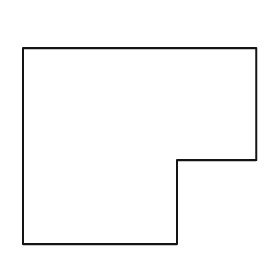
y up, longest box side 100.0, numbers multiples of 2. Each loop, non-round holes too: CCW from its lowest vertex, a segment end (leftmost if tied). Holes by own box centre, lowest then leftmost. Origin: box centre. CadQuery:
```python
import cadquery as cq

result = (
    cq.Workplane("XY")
    .moveTo(-50.0, -42.0)
    .lineTo(16.0, -42.0)
    .lineTo(16.0, -6.0)
    .lineTo(50.0, -6.0)
    .lineTo(50.0, 42.0)
    .lineTo(-50.0, 42.0)
    .close()
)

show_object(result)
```